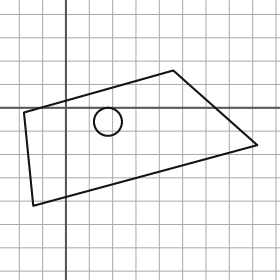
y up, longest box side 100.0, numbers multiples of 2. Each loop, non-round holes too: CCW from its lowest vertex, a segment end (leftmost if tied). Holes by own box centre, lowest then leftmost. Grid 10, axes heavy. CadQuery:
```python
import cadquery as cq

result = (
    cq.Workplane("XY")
    .moveTo(-14.0, -42.0)
    .lineTo(82.0, -16.0)
    .lineTo(46.0, 16.0)
    .lineTo(-18.0, -2.0)
    .close()
    .moveTo(18.0, -6.0)
    .circle(6.0)
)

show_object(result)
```